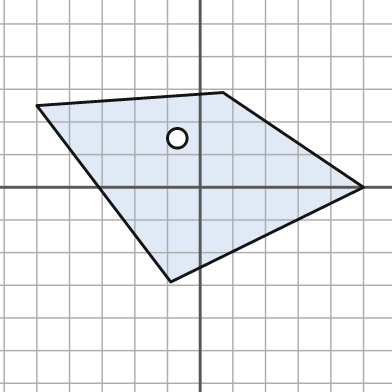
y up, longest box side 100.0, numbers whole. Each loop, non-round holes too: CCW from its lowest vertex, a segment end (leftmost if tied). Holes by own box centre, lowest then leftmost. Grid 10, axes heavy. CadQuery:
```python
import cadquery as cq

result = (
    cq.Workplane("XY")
    .moveTo(-9.0, -29.0)
    .lineTo(50.0, 0.0)
    .lineTo(7.0, 29.0)
    .lineTo(-50.0, 25.0)
    .close()
    .moveTo(-7.0, 15.0)
    .circle(3.0)
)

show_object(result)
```